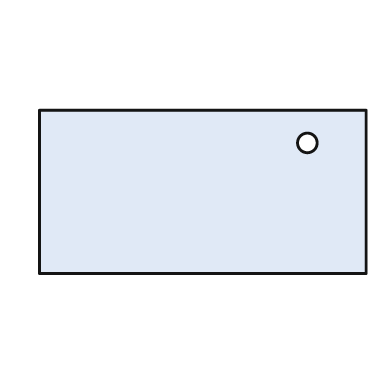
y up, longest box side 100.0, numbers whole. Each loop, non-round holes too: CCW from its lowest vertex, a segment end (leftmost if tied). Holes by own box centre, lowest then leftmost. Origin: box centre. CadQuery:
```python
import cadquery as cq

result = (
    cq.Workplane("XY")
    .moveTo(-50.0, -25.0)
    .lineTo(50.0, -25.0)
    .lineTo(50.0, 25.0)
    .lineTo(-50.0, 25.0)
    .close()
    .moveTo(32.0, 15.0)
    .circle(3.0)
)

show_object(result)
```